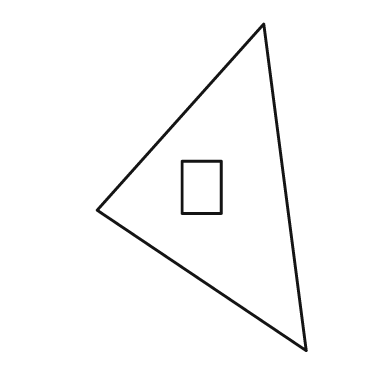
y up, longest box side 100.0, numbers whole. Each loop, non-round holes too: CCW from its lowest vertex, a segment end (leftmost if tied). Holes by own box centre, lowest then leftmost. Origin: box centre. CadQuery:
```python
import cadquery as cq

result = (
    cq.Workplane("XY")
    .moveTo(32.0, -50.0)
    .lineTo(19.0, 50.0)
    .lineTo(-32.0, -7.0)
    .close()
    .moveTo(-6.0, -8.0)
    .lineTo(6.0, -8.0)
    .lineTo(6.0, 8.0)
    .lineTo(-6.0, 8.0)
    .close()
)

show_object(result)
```